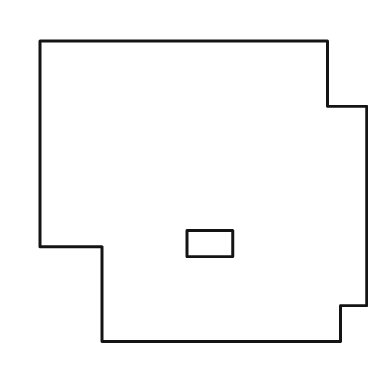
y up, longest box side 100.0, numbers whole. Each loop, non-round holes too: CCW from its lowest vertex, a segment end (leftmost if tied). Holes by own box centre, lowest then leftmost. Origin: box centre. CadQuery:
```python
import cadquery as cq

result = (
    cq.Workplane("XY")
    .moveTo(-31.0, -46.0)
    .lineTo(42.0, -46.0)
    .lineTo(42.0, -35.0)
    .lineTo(50.0, -35.0)
    .lineTo(50.0, 26.0)
    .lineTo(38.0, 26.0)
    .lineTo(38.0, 46.0)
    .lineTo(-50.0, 46.0)
    .lineTo(-50.0, -17.0)
    .lineTo(-31.0, -17.0)
    .close()
    .moveTo(-5.0, -20.0)
    .lineTo(9.0, -20.0)
    .lineTo(9.0, -12.0)
    .lineTo(-5.0, -12.0)
    .close()
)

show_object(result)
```